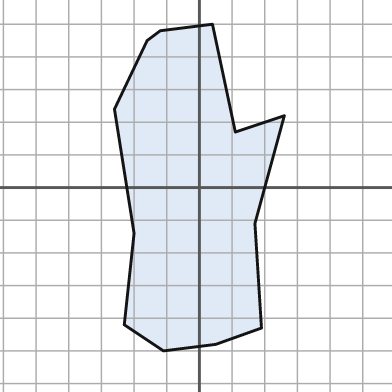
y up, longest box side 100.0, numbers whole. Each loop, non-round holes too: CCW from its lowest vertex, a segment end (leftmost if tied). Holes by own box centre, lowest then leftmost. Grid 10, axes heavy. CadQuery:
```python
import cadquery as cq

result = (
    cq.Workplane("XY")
    .moveTo(-11.0, -50.0)
    .lineTo(5.0, -48.0)
    .lineTo(19.0, -43.0)
    .lineTo(17.0, -11.0)
    .lineTo(26.0, 22.0)
    .lineTo(11.0, 17.0)
    .lineTo(4.0, 50.0)
    .lineTo(-12.0, 48.0)
    .lineTo(-16.0, 45.0)
    .lineTo(-26.0, 24.0)
    .lineTo(-20.0, -14.0)
    .lineTo(-23.0, -42.0)
    .close()
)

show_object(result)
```